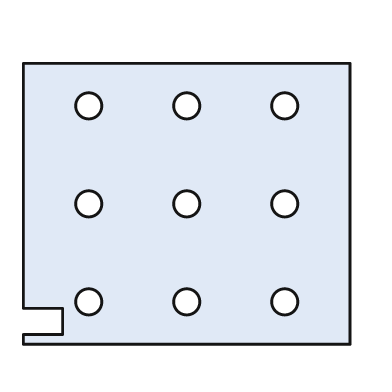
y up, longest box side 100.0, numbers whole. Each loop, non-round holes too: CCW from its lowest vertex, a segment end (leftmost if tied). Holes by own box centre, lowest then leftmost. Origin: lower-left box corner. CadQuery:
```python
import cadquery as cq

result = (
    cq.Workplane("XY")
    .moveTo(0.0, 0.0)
    .lineTo(100.0, 0.0)
    .lineTo(100.0, 86.0)
    .lineTo(0.0, 86.0)
    .lineTo(0.0, 11.0)
    .lineTo(12.0, 11.0)
    .lineTo(12.0, 3.0)
    .lineTo(0.0, 3.0)
    .close()
    .moveTo(20.0, 13.0)
    .circle(4.0)
    .moveTo(50.0, 13.0)
    .circle(4.0)
    .moveTo(80.0, 13.0)
    .circle(4.0)
    .moveTo(20.0, 43.0)
    .circle(4.0)
    .moveTo(50.0, 43.0)
    .circle(4.0)
    .moveTo(80.0, 43.0)
    .circle(4.0)
    .moveTo(20.0, 73.0)
    .circle(4.0)
    .moveTo(50.0, 73.0)
    .circle(4.0)
    .moveTo(80.0, 73.0)
    .circle(4.0)
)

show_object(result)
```